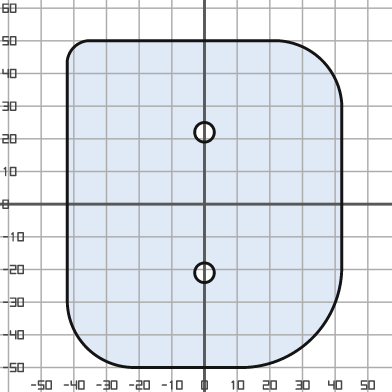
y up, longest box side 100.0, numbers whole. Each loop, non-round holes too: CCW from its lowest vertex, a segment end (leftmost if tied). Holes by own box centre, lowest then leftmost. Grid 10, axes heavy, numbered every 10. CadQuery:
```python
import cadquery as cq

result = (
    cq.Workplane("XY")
    .moveTo(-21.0, -50.0)
    .lineTo(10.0, -50.0)
    .threePointArc((33.0, -41.0), (42.0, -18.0))
    .lineTo(42.0, 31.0)
    .threePointArc((36.0, 44.0), (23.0, 50.0))
    .lineTo(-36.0, 50.0)
    .threePointArc((-40.0, 48.0), (-42.0, 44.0))
    .lineTo(-42.0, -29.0)
    .threePointArc((-36.0, -44.0), (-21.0, -50.0))
    .close()
    .moveTo(0.0, -21.0)
    .circle(3.0)
    .moveTo(0.0, 22.0)
    .circle(3.0)
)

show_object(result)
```